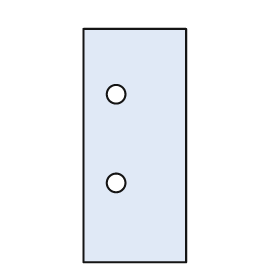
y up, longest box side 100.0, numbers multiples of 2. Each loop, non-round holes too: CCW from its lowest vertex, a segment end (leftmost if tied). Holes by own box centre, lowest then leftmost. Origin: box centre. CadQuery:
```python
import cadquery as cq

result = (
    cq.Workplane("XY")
    .moveTo(-22.0, -50.0)
    .lineTo(22.0, -50.0)
    .lineTo(22.0, 50.0)
    .lineTo(-22.0, 50.0)
    .close()
    .moveTo(-8.0, -16.0)
    .circle(4.0)
    .moveTo(-8.0, 22.0)
    .circle(4.0)
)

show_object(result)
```